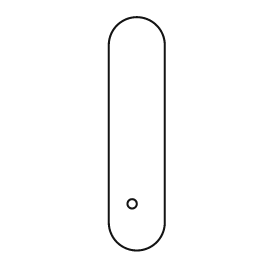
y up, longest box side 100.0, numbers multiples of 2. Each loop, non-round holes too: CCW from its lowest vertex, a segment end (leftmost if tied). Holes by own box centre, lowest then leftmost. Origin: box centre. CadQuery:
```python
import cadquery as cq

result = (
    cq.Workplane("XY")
    .moveTo(-12.0, -38.0)
    .threePointArc((0.0, -50.0), (12.0, -38.0))
    .lineTo(12.0, 38.0)
    .threePointArc((0.0, 50.0), (-12.0, 38.0))
    .close()
    .moveTo(-2.0, -30.0)
    .circle(2.0)
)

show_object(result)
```